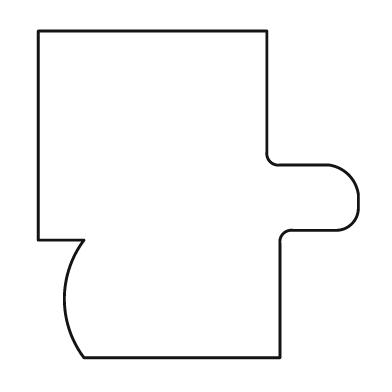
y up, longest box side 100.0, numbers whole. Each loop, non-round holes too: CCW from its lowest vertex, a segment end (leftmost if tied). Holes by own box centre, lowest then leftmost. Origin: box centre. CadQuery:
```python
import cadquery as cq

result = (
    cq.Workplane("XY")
    .moveTo(-35.0, -50.0)
    .lineTo(25.0, -50.0)
    .lineTo(25.0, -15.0)
    .threePointArc((26.0, -12.0), (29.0, -11.0))
    .lineTo(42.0, -11.0)
    .threePointArc((47.0, -9.0), (49.0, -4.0))
    .lineTo(49.0, 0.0)
    .threePointArc((46.0, 6.0), (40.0, 9.0))
    .lineTo(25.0, 9.0)
    .threePointArc((22.0, 10.0), (21.0, 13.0))
    .lineTo(21.0, 50.0)
    .lineTo(-49.0, 50.0)
    .lineTo(-49.0, -14.0)
    .lineTo(-35.0, -14.0)
    .threePointArc((-41.0, -32.0), (-35.0, -50.0))
    .close()
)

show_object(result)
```